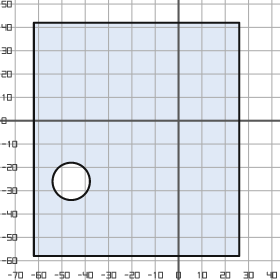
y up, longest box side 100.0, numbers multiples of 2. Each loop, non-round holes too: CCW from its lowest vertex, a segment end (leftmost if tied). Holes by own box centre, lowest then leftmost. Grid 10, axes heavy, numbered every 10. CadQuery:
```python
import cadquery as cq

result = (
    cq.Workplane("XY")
    .moveTo(-62.0, -58.0)
    .lineTo(26.0, -58.0)
    .lineTo(26.0, 42.0)
    .lineTo(-62.0, 42.0)
    .close()
    .moveTo(-46.0, -26.0)
    .circle(8.0)
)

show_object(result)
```